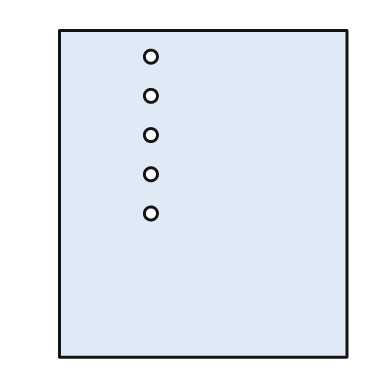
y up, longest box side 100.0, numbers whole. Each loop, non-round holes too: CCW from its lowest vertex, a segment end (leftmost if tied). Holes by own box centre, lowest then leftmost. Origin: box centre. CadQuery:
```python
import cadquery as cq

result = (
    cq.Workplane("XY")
    .moveTo(-44.0, -50.0)
    .lineTo(44.0, -50.0)
    .lineTo(44.0, 50.0)
    .lineTo(-44.0, 50.0)
    .close()
    .moveTo(-16.0, -6.0)
    .circle(2.0)
    .moveTo(-16.0, 6.0)
    .circle(2.0)
    .moveTo(-16.0, 18.0)
    .circle(2.0)
    .moveTo(-16.0, 30.0)
    .circle(2.0)
    .moveTo(-16.0, 42.0)
    .circle(2.0)
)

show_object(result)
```